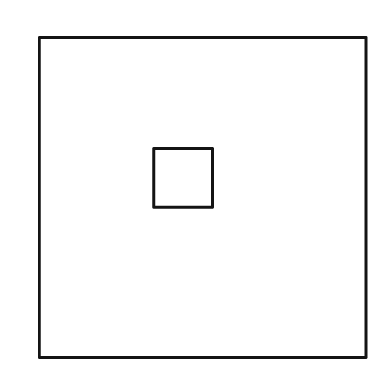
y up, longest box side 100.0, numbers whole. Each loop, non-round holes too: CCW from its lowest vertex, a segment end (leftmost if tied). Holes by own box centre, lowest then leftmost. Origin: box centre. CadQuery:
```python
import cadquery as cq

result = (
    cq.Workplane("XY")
    .moveTo(-50.0, -49.0)
    .lineTo(50.0, -49.0)
    .lineTo(50.0, 49.0)
    .lineTo(-50.0, 49.0)
    .close()
    .moveTo(-15.0, -3.0)
    .lineTo(3.0, -3.0)
    .lineTo(3.0, 15.0)
    .lineTo(-15.0, 15.0)
    .close()
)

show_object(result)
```